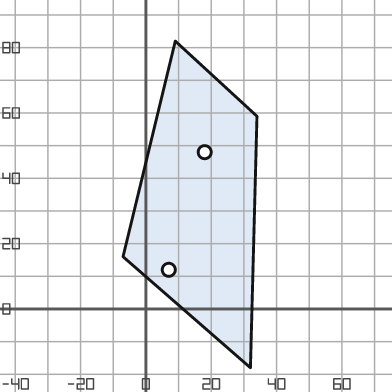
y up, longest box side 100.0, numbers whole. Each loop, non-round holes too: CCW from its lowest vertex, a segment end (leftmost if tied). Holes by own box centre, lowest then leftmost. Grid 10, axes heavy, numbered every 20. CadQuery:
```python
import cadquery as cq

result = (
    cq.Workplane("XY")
    .moveTo(32.0, -18.0)
    .lineTo(34.0, 59.0)
    .lineTo(9.0, 82.0)
    .lineTo(-7.0, 16.0)
    .close()
    .moveTo(7.0, 12.0)
    .circle(2.0)
    .moveTo(18.0, 48.0)
    .circle(2.0)
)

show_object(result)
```